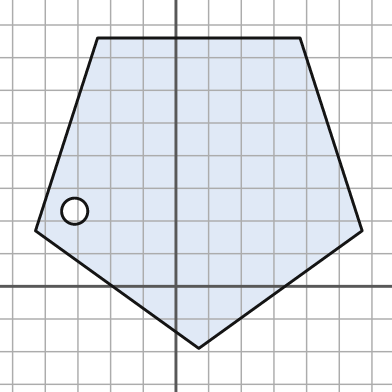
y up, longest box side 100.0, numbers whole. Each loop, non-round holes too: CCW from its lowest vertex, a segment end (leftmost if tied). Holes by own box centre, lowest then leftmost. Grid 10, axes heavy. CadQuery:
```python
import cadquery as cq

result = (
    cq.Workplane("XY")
    .moveTo(7.0, -19.0)
    .lineTo(57.0, 17.0)
    .lineTo(38.0, 76.0)
    .lineTo(-24.0, 76.0)
    .lineTo(-43.0, 17.0)
    .close()
    .moveTo(-31.0, 23.0)
    .circle(4.0)
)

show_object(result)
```